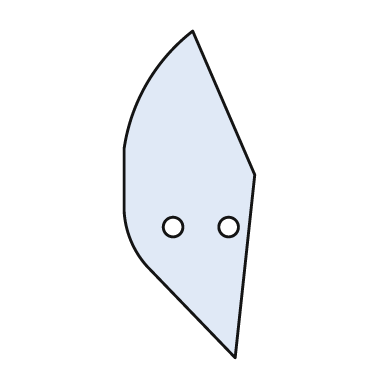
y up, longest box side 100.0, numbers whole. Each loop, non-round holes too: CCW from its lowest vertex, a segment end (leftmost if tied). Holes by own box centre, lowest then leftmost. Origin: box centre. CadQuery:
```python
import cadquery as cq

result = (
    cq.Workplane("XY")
    .moveTo(14.0, -50.0)
    .lineTo(20.0, 6.0)
    .lineTo(1.0, 50.0)
    .threePointArc((-13.0, 34.0), (-20.0, 14.0))
    .lineTo(-20.0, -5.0)
    .threePointArc((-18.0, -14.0), (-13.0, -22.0))
    .close()
    .moveTo(-5.0, -10.0)
    .circle(3.0)
    .moveTo(12.0, -10.0)
    .circle(3.0)
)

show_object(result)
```